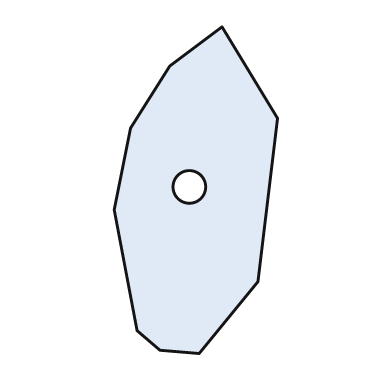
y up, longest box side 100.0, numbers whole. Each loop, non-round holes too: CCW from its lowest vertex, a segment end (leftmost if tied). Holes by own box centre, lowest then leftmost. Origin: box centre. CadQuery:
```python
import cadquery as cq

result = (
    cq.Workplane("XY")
    .moveTo(1.0, -50.0)
    .lineTo(19.0, -28.0)
    .lineTo(25.0, 22.0)
    .lineTo(8.0, 50.0)
    .lineTo(-8.0, 38.0)
    .lineTo(-20.0, 19.0)
    .lineTo(-25.0, -6.0)
    .lineTo(-18.0, -43.0)
    .lineTo(-11.0, -49.0)
    .close()
    .moveTo(-2.0, 1.0)
    .circle(5.0)
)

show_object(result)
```